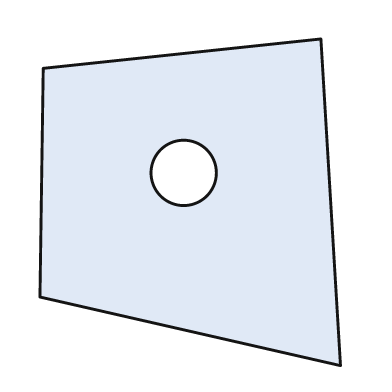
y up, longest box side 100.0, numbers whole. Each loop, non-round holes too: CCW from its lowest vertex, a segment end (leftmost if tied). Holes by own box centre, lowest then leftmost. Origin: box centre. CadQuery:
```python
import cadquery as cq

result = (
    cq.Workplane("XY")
    .moveTo(46.0, -50.0)
    .lineTo(40.0, 50.0)
    .lineTo(-45.0, 41.0)
    .lineTo(-46.0, -29.0)
    .close()
    .moveTo(-2.0, 9.0)
    .circle(10.0)
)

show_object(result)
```